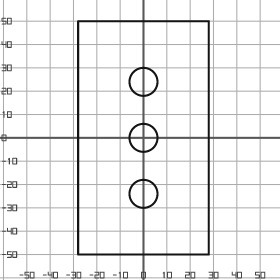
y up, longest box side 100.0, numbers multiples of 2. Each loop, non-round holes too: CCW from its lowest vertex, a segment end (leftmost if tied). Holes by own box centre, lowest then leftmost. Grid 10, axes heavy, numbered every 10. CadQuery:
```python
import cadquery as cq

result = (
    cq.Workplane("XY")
    .moveTo(-28.0, -50.0)
    .lineTo(28.0, -50.0)
    .lineTo(28.0, 50.0)
    .lineTo(-28.0, 50.0)
    .close()
    .moveTo(0.0, -24.0)
    .circle(6.0)
    .moveTo(0.0, 0.0)
    .circle(6.0)
    .moveTo(0.0, 24.0)
    .circle(6.0)
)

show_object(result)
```